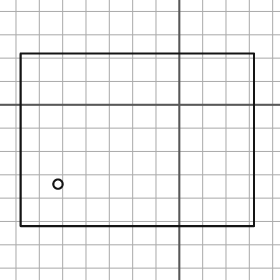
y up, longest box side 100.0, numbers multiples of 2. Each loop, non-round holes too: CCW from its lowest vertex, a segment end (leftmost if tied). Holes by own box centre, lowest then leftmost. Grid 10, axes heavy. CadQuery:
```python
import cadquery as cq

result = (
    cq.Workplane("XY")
    .moveTo(-68.0, -52.0)
    .lineTo(32.0, -52.0)
    .lineTo(32.0, 22.0)
    .lineTo(-68.0, 22.0)
    .close()
    .moveTo(-52.0, -34.0)
    .circle(2.0)
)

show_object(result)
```